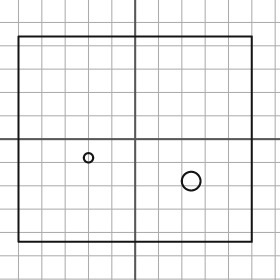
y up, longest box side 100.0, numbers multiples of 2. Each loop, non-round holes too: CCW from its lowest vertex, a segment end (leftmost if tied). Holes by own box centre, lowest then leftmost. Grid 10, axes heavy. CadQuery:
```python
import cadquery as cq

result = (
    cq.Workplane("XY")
    .moveTo(-50.0, -44.0)
    .lineTo(50.0, -44.0)
    .lineTo(50.0, 44.0)
    .lineTo(-50.0, 44.0)
    .close()
    .moveTo(24.0, -18.0)
    .circle(4.0)
    .moveTo(-20.0, -8.0)
    .circle(2.0)
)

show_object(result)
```